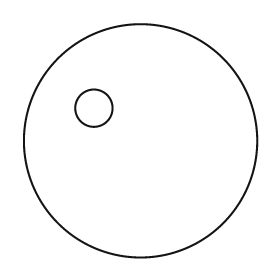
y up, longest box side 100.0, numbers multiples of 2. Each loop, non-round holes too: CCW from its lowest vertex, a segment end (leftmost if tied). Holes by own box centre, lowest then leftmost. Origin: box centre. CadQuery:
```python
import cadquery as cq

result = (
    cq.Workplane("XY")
    .moveTo(0.0, 0.0)
    .circle(50.0)
    .moveTo(-20.0, 14.0)
    .circle(8.0)
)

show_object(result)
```